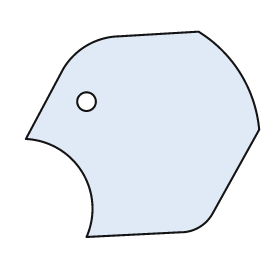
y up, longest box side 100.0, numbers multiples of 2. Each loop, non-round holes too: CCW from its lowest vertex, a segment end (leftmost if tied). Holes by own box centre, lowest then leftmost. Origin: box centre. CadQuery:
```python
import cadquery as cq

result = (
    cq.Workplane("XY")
    .moveTo(-24.0, -44.0)
    .lineTo(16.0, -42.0)
    .threePointArc((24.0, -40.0), (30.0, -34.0))
    .lineTo(50.0, 2.0)
    .threePointArc((42.0, 26.0), (24.0, 44.0))
    .lineTo(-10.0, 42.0)
    .threePointArc((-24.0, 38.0), (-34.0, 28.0))
    .lineTo(-50.0, -2.0)
    .threePointArc((-26.0, -16.0), (-24.0, -44.0))
    .close()
    .moveTo(-24.0, 14.0)
    .circle(4.0)
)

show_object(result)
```